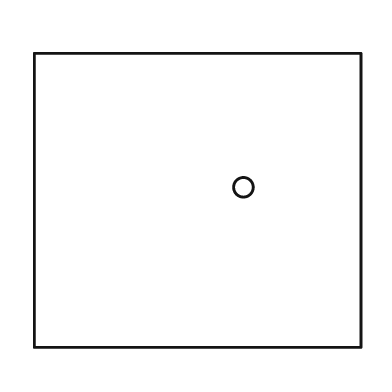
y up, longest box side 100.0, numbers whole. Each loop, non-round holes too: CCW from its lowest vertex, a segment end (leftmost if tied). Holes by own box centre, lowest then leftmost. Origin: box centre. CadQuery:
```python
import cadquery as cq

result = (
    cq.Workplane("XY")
    .moveTo(-50.0, -45.0)
    .lineTo(50.0, -45.0)
    .lineTo(50.0, 45.0)
    .lineTo(-50.0, 45.0)
    .close()
    .moveTo(14.0, 4.0)
    .circle(3.0)
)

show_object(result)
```